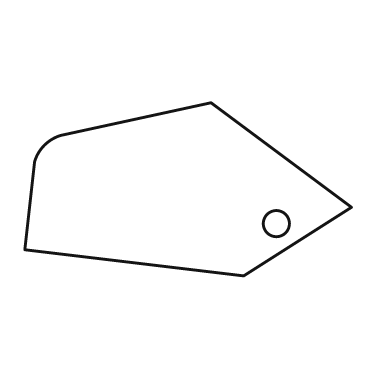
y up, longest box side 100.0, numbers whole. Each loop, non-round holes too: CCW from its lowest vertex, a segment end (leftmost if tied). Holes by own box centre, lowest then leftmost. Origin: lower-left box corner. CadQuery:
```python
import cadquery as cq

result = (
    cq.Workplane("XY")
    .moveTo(67.0, 0.0)
    .lineTo(100.0, 21.0)
    .lineTo(57.0, 53.0)
    .lineTo(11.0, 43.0)
    .threePointArc((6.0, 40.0), (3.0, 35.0))
    .lineTo(0.0, 8.0)
    .close()
    .moveTo(77.0, 16.0)
    .circle(4.0)
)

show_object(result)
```